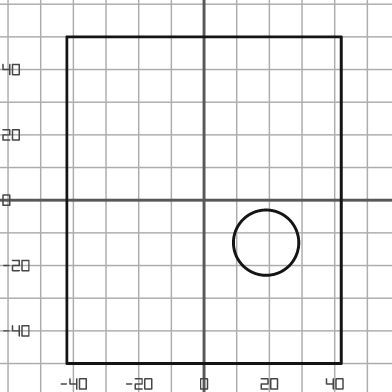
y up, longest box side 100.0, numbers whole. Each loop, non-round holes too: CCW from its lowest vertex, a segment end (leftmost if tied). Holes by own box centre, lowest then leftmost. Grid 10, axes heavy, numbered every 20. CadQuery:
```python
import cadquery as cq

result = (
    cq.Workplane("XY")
    .moveTo(-42.0, -50.0)
    .lineTo(42.0, -50.0)
    .lineTo(42.0, 50.0)
    .lineTo(-42.0, 50.0)
    .close()
    .moveTo(19.0, -13.0)
    .circle(10.0)
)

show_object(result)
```